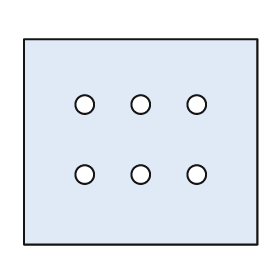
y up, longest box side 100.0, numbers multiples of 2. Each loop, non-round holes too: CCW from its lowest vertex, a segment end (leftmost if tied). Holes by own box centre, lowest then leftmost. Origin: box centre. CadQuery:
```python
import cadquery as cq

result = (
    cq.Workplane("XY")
    .moveTo(-50.0, -44.0)
    .lineTo(50.0, -44.0)
    .lineTo(50.0, 44.0)
    .lineTo(-50.0, 44.0)
    .close()
    .moveTo(-24.0, -14.0)
    .circle(4.0)
    .moveTo(0.0, -14.0)
    .circle(4.0)
    .moveTo(24.0, -14.0)
    .circle(4.0)
    .moveTo(-24.0, 16.0)
    .circle(4.0)
    .moveTo(0.0, 16.0)
    .circle(4.0)
    .moveTo(24.0, 16.0)
    .circle(4.0)
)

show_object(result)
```